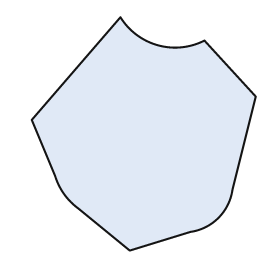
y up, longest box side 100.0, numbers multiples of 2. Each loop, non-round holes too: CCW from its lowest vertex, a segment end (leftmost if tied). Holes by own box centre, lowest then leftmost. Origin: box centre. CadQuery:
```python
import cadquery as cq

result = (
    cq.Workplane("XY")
    .moveTo(-6.0, -50.0)
    .lineTo(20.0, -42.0)
    .threePointArc((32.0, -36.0), (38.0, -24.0))
    .lineTo(48.0, 16.0)
    .lineTo(26.0, 40.0)
    .threePointArc((6.0, 38.0), (-10.0, 50.0))
    .lineTo(-48.0, 6.0)
    .lineTo(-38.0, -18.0)
    .threePointArc((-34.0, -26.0), (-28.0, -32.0))
    .close()
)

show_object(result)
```